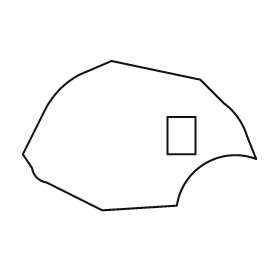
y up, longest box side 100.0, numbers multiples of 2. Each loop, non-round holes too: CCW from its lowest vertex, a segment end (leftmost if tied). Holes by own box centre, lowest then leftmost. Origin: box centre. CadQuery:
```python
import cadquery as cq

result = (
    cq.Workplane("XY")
    .moveTo(-16.0, -32.0)
    .lineTo(16.0, -30.0)
    .threePointArc((28.0, -12.0), (50.0, -10.0))
    .lineTo(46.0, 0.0)
    .threePointArc((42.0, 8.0), (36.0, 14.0))
    .lineTo(26.0, 24.0)
    .lineTo(-12.0, 32.0)
    .lineTo(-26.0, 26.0)
    .threePointArc((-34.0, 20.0), (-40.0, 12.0))
    .lineTo(-50.0, -8.0)
    .lineTo(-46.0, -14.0)
    .threePointArc((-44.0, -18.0), (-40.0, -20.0))
    .close()
    .moveTo(12.0, -8.0)
    .lineTo(24.0, -8.0)
    .lineTo(24.0, 8.0)
    .lineTo(12.0, 8.0)
    .close()
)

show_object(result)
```